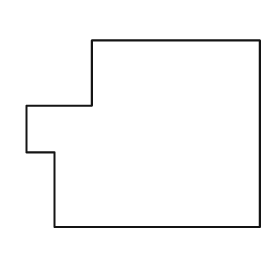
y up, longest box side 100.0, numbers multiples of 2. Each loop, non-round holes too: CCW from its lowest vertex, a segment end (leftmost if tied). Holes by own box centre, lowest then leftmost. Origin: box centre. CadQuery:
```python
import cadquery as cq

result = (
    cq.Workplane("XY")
    .moveTo(-38.0, -40.0)
    .lineTo(50.0, -40.0)
    .lineTo(50.0, 40.0)
    .lineTo(-22.0, 40.0)
    .lineTo(-22.0, 12.0)
    .lineTo(-50.0, 12.0)
    .lineTo(-50.0, -8.0)
    .lineTo(-38.0, -8.0)
    .close()
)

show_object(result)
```